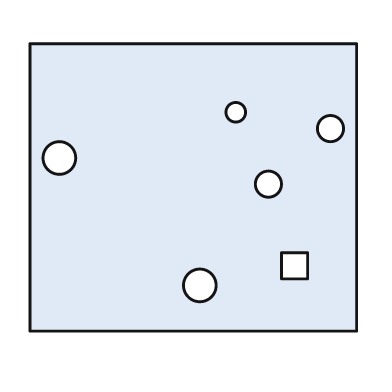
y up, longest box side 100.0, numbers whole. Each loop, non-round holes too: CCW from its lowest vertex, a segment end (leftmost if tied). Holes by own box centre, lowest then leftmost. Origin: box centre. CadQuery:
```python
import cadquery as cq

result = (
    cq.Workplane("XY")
    .moveTo(-50.0, -44.0)
    .lineTo(50.0, -44.0)
    .lineTo(50.0, 44.0)
    .lineTo(-50.0, 44.0)
    .close()
    .moveTo(2.0, -30.0)
    .circle(5.0)
    .moveTo(27.0, -28.0)
    .lineTo(35.0, -28.0)
    .lineTo(35.0, -20.0)
    .lineTo(27.0, -20.0)
    .close()
    .moveTo(23.0, 1.0)
    .circle(4.0)
    .moveTo(-41.0, 9.0)
    .circle(5.0)
    .moveTo(42.0, 18.0)
    .circle(4.0)
    .moveTo(13.0, 23.0)
    .circle(3.0)
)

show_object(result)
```